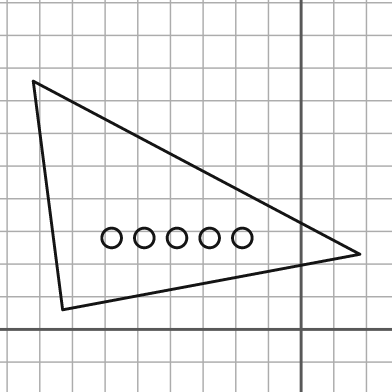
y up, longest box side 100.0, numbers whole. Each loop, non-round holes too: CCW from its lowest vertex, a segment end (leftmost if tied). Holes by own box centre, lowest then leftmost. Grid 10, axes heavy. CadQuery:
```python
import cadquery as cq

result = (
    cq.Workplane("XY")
    .moveTo(-73.0, 6.0)
    .lineTo(18.0, 23.0)
    .lineTo(-82.0, 76.0)
    .close()
    .moveTo(-58.0, 28.0)
    .circle(3.0)
    .moveTo(-48.0, 28.0)
    .circle(3.0)
    .moveTo(-38.0, 28.0)
    .circle(3.0)
    .moveTo(-28.0, 28.0)
    .circle(3.0)
    .moveTo(-18.0, 28.0)
    .circle(3.0)
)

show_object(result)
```